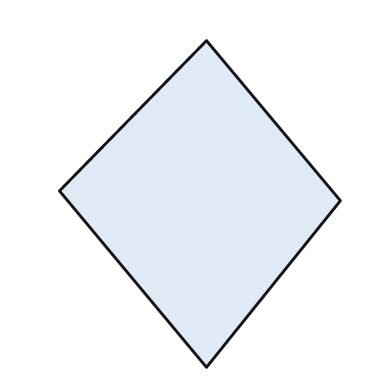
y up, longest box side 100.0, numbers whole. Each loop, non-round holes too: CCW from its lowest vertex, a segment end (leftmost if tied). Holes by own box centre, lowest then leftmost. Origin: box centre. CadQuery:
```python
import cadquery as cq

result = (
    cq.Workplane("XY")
    .moveTo(2.0, -50.0)
    .lineTo(43.0, 1.0)
    .lineTo(2.0, 50.0)
    .lineTo(-43.0, 4.0)
    .close()
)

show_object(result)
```